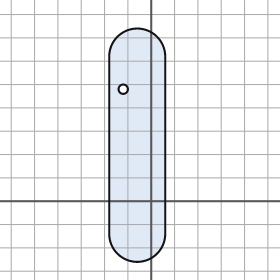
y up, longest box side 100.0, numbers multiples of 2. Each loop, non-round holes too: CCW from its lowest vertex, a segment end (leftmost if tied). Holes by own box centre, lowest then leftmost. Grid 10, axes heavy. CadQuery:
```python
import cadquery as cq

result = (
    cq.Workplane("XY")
    .moveTo(-18.0, -14.0)
    .threePointArc((-6.0, -26.0), (6.0, -14.0))
    .lineTo(6.0, 62.0)
    .threePointArc((-6.0, 74.0), (-18.0, 62.0))
    .close()
    .moveTo(-12.0, 48.0)
    .circle(2.0)
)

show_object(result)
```